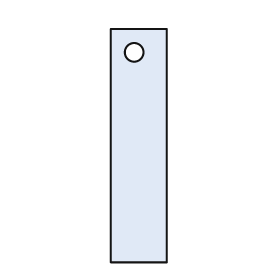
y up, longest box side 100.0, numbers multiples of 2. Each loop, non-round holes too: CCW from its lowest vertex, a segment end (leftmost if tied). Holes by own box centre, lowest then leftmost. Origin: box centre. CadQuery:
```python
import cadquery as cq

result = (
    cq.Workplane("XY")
    .moveTo(-12.0, -50.0)
    .lineTo(12.0, -50.0)
    .lineTo(12.0, 50.0)
    .lineTo(-12.0, 50.0)
    .close()
    .moveTo(-2.0, 40.0)
    .circle(4.0)
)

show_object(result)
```